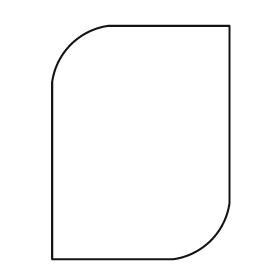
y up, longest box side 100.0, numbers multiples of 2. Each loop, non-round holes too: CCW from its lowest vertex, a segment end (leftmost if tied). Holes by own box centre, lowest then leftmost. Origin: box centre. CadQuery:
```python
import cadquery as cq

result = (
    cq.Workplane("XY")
    .moveTo(-38.0, -50.0)
    .lineTo(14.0, -50.0)
    .threePointArc((30.0, -42.0), (38.0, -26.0))
    .lineTo(38.0, 50.0)
    .lineTo(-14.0, 50.0)
    .threePointArc((-30.0, 42.0), (-38.0, 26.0))
    .close()
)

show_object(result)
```